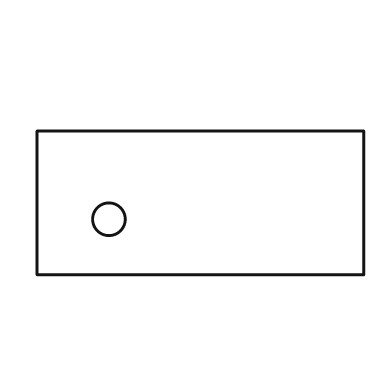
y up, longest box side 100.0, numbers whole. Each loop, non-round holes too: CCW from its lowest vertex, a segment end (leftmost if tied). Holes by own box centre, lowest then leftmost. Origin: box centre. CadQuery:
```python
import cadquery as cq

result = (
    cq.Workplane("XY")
    .moveTo(-50.0, -22.0)
    .lineTo(50.0, -22.0)
    .lineTo(50.0, 22.0)
    .lineTo(-50.0, 22.0)
    .close()
    .moveTo(-28.0, -5.0)
    .circle(5.0)
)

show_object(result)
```